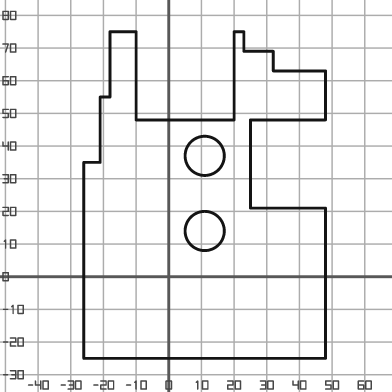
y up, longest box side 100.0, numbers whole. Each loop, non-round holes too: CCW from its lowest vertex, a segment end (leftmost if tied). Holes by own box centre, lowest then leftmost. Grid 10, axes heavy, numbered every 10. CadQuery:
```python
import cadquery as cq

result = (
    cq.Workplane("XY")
    .moveTo(-26.0, -25.0)
    .lineTo(48.0, -25.0)
    .lineTo(48.0, 21.0)
    .lineTo(25.0, 21.0)
    .lineTo(25.0, 48.0)
    .lineTo(48.0, 48.0)
    .lineTo(48.0, 63.0)
    .lineTo(32.0, 63.0)
    .lineTo(32.0, 69.0)
    .lineTo(23.0, 69.0)
    .lineTo(23.0, 75.0)
    .lineTo(20.0, 75.0)
    .lineTo(20.0, 48.0)
    .lineTo(-10.0, 48.0)
    .lineTo(-10.0, 75.0)
    .lineTo(-18.0, 75.0)
    .lineTo(-18.0, 55.0)
    .lineTo(-21.0, 55.0)
    .lineTo(-21.0, 35.0)
    .lineTo(-26.0, 35.0)
    .close()
    .moveTo(11.0, 14.0)
    .circle(6.0)
    .moveTo(11.0, 37.0)
    .circle(6.0)
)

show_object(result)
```